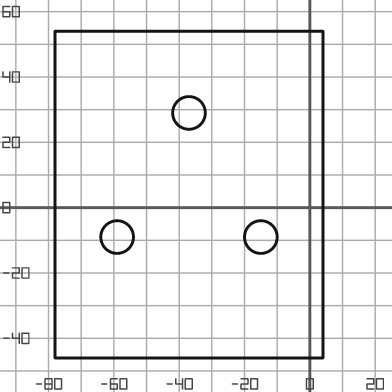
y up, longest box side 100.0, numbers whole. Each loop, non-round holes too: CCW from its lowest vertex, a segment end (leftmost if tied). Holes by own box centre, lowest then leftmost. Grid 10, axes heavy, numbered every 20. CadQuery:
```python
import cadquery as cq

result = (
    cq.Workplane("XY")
    .moveTo(-78.0, -46.0)
    .lineTo(4.0, -46.0)
    .lineTo(4.0, 54.0)
    .lineTo(-78.0, 54.0)
    .close()
    .moveTo(-59.0, -9.0)
    .circle(5.0)
    .moveTo(-15.0, -9.0)
    .circle(5.0)
    .moveTo(-37.0, 29.0)
    .circle(5.0)
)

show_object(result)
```